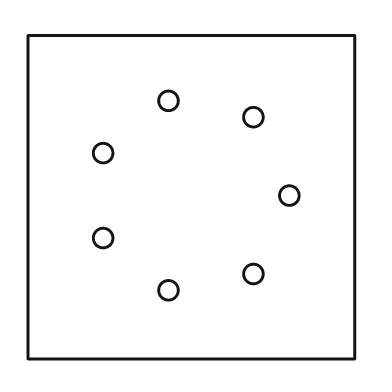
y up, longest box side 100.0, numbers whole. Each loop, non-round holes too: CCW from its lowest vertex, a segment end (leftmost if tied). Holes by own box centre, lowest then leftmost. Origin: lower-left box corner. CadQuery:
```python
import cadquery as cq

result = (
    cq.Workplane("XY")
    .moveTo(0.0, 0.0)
    .lineTo(100.0, 0.0)
    .lineTo(100.0, 99.0)
    .lineTo(0.0, 99.0)
    .close()
    .moveTo(43.0, 21.0)
    .circle(3.0)
    .moveTo(69.0, 26.0)
    .circle(3.0)
    .moveTo(23.0, 37.0)
    .circle(3.0)
    .moveTo(80.0, 50.0)
    .circle(3.0)
    .moveTo(23.0, 63.0)
    .circle(3.0)
    .moveTo(69.0, 74.0)
    .circle(3.0)
    .moveTo(43.0, 79.0)
    .circle(3.0)
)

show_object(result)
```